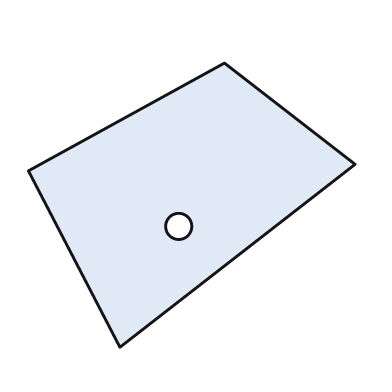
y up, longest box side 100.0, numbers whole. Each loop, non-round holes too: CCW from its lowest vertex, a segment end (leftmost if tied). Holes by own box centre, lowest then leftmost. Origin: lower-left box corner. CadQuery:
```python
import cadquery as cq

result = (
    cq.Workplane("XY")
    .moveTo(28.0, 0.0)
    .lineTo(100.0, 56.0)
    .lineTo(60.0, 87.0)
    .lineTo(0.0, 54.0)
    .close()
    .moveTo(46.0, 37.0)
    .circle(4.0)
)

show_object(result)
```